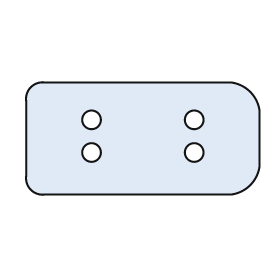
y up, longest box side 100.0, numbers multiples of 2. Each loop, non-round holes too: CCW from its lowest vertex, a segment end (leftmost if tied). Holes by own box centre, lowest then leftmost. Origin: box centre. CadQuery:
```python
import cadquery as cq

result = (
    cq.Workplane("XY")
    .moveTo(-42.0, -24.0)
    .lineTo(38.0, -24.0)
    .threePointArc((46.0, -20.0), (50.0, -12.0))
    .lineTo(50.0, 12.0)
    .threePointArc((46.0, 20.0), (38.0, 24.0))
    .lineTo(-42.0, 24.0)
    .threePointArc((-48.0, 22.0), (-50.0, 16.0))
    .lineTo(-50.0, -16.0)
    .threePointArc((-48.0, -22.0), (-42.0, -24.0))
    .close()
    .moveTo(-22.0, -6.0)
    .circle(4.0)
    .moveTo(22.0, -6.0)
    .circle(4.0)
    .moveTo(-22.0, 8.0)
    .circle(4.0)
    .moveTo(22.0, 8.0)
    .circle(4.0)
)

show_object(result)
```